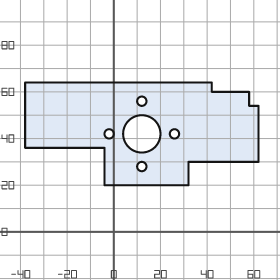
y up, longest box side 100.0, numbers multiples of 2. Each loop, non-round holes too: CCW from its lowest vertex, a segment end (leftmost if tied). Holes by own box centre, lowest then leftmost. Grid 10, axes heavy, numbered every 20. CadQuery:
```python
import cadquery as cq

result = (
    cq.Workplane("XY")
    .moveTo(-4.0, 20.0)
    .lineTo(32.0, 20.0)
    .lineTo(32.0, 30.0)
    .lineTo(62.0, 30.0)
    .lineTo(62.0, 54.0)
    .lineTo(58.0, 54.0)
    .lineTo(58.0, 60.0)
    .lineTo(42.0, 60.0)
    .lineTo(42.0, 64.0)
    .lineTo(-38.0, 64.0)
    .lineTo(-38.0, 36.0)
    .lineTo(-4.0, 36.0)
    .close()
    .moveTo(12.0, 28.0)
    .circle(2.0)
    .moveTo(-2.0, 42.0)
    .circle(2.0)
    .moveTo(12.0, 42.0)
    .circle(8.0)
    .moveTo(26.0, 42.0)
    .circle(2.0)
    .moveTo(12.0, 56.0)
    .circle(2.0)
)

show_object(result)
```